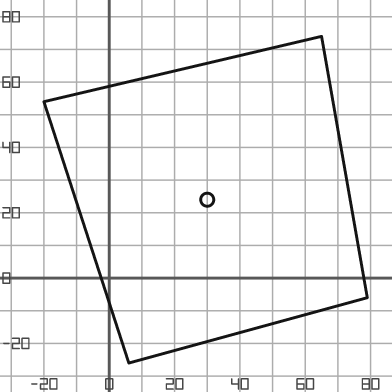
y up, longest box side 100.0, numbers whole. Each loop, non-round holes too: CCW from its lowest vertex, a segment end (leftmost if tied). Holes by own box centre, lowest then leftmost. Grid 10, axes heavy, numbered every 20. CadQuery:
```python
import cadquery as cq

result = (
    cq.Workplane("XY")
    .moveTo(6.0, -26.0)
    .lineTo(79.0, -6.0)
    .lineTo(65.0, 74.0)
    .lineTo(-20.0, 54.0)
    .close()
    .moveTo(30.0, 24.0)
    .circle(2.0)
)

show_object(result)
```